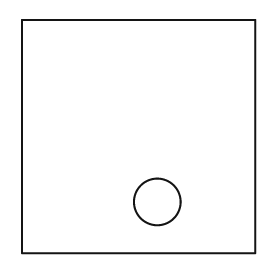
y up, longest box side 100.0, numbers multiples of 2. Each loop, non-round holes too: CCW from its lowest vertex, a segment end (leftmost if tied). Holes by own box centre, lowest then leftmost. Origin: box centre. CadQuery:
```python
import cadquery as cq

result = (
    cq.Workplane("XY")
    .moveTo(-50.0, -50.0)
    .lineTo(50.0, -50.0)
    .lineTo(50.0, 50.0)
    .lineTo(-50.0, 50.0)
    .close()
    .moveTo(8.0, -28.0)
    .circle(10.0)
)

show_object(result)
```